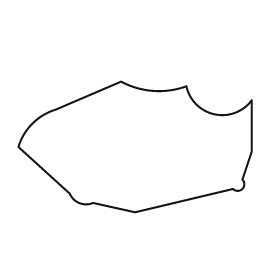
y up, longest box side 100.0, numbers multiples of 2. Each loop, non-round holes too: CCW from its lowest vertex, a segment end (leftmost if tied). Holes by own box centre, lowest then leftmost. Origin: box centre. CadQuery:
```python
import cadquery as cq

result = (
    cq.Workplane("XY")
    .moveTo(0.0, -28.0)
    .lineTo(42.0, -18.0)
    .threePointArc((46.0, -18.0), (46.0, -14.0))
    .lineTo(50.0, -2.0)
    .lineTo(50.0, 20.0)
    .threePointArc((34.0, 14.0), (22.0, 26.0))
    .threePointArc((8.0, 24.0), (-6.0, 28.0))
    .lineTo(-34.0, 16.0)
    .threePointArc((-44.0, 10.0), (-50.0, 0.0))
    .lineTo(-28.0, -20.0)
    .threePointArc((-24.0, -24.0), (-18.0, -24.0))
    .close()
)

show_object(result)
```